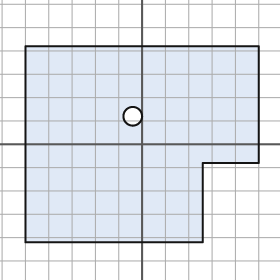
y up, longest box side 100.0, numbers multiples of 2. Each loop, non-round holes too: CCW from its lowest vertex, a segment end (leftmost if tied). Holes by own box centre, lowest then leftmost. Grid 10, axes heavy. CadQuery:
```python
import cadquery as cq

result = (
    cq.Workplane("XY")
    .moveTo(-50.0, -42.0)
    .lineTo(26.0, -42.0)
    .lineTo(26.0, -8.0)
    .lineTo(50.0, -8.0)
    .lineTo(50.0, 42.0)
    .lineTo(-50.0, 42.0)
    .close()
    .moveTo(-4.0, 12.0)
    .circle(4.0)
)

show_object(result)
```